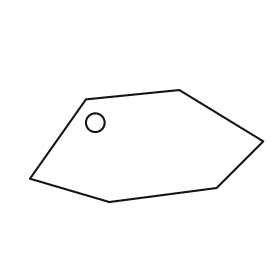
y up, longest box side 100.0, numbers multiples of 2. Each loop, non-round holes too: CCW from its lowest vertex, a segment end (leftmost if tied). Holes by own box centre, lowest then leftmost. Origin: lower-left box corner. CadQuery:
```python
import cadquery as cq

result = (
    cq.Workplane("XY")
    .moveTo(34.0, 0.0)
    .lineTo(80.0, 6.0)
    .lineTo(100.0, 26.0)
    .lineTo(64.0, 48.0)
    .lineTo(24.0, 44.0)
    .lineTo(0.0, 10.0)
    .close()
    .moveTo(28.0, 34.0)
    .circle(4.0)
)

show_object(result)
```